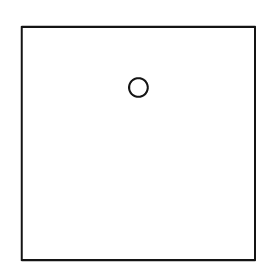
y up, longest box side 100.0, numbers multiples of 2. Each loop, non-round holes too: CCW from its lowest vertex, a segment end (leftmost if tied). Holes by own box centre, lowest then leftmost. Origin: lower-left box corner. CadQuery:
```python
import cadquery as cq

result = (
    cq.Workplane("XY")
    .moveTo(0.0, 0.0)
    .lineTo(100.0, 0.0)
    .lineTo(100.0, 100.0)
    .lineTo(0.0, 100.0)
    .close()
    .moveTo(50.0, 74.0)
    .circle(4.0)
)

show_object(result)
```